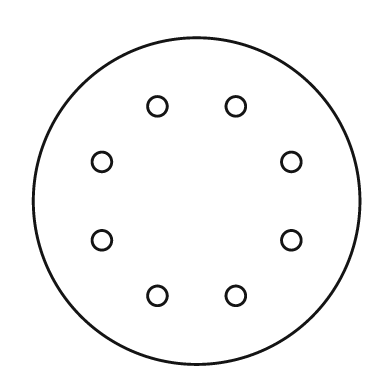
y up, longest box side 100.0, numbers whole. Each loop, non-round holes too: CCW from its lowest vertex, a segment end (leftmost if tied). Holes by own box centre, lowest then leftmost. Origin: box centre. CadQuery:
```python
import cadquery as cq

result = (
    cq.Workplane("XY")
    .moveTo(0.0, 0.0)
    .circle(50.0)
    .moveTo(-12.0, -29.0)
    .circle(3.0)
    .moveTo(12.0, -29.0)
    .circle(3.0)
    .moveTo(-29.0, -12.0)
    .circle(3.0)
    .moveTo(29.0, -12.0)
    .circle(3.0)
    .moveTo(-29.0, 12.0)
    .circle(3.0)
    .moveTo(29.0, 12.0)
    .circle(3.0)
    .moveTo(-12.0, 29.0)
    .circle(3.0)
    .moveTo(12.0, 29.0)
    .circle(3.0)
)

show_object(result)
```